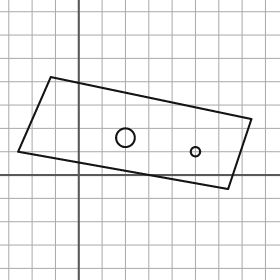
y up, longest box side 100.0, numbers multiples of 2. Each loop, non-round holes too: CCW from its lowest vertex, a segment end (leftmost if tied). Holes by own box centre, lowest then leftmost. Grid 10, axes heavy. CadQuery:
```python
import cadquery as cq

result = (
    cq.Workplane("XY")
    .moveTo(64.0, -6.0)
    .lineTo(74.0, 24.0)
    .lineTo(-12.0, 42.0)
    .lineTo(-26.0, 10.0)
    .close()
    .moveTo(50.0, 10.0)
    .circle(2.0)
    .moveTo(20.0, 16.0)
    .circle(4.0)
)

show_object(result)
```